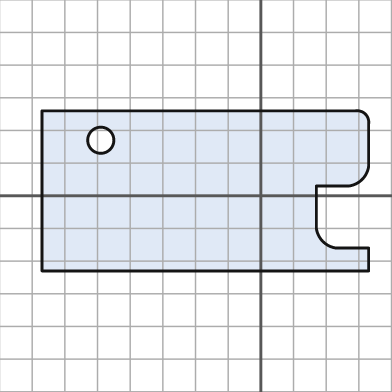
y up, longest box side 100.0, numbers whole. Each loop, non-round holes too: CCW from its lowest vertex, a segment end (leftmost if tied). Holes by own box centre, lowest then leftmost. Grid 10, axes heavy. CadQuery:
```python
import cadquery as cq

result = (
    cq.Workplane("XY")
    .moveTo(-67.0, -23.0)
    .lineTo(33.0, -23.0)
    .lineTo(33.0, -16.0)
    .lineTo(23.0, -16.0)
    .threePointArc((19.0, -14.0), (17.0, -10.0))
    .lineTo(17.0, 3.0)
    .lineTo(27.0, 3.0)
    .threePointArc((31.0, 5.0), (33.0, 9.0))
    .lineTo(33.0, 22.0)
    .threePointArc((32.0, 25.0), (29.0, 26.0))
    .lineTo(-67.0, 26.0)
    .close()
    .moveTo(-49.0, 17.0)
    .circle(4.0)
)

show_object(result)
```